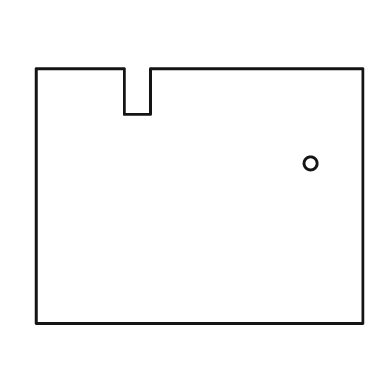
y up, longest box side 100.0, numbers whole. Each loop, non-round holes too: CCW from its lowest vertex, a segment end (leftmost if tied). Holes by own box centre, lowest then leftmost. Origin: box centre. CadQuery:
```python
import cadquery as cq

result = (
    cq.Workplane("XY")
    .moveTo(-50.0, -39.0)
    .lineTo(50.0, -39.0)
    .lineTo(50.0, 39.0)
    .lineTo(-15.0, 39.0)
    .lineTo(-15.0, 25.0)
    .lineTo(-23.0, 25.0)
    .lineTo(-23.0, 39.0)
    .lineTo(-50.0, 39.0)
    .close()
    .moveTo(34.0, 10.0)
    .circle(2.0)
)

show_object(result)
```